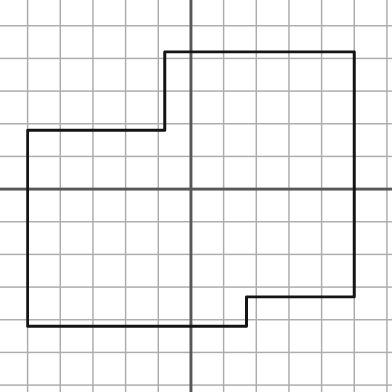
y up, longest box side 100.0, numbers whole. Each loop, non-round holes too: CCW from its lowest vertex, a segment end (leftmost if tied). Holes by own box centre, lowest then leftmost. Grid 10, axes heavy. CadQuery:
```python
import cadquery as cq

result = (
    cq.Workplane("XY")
    .moveTo(-50.0, -42.0)
    .lineTo(17.0, -42.0)
    .lineTo(17.0, -33.0)
    .lineTo(50.0, -33.0)
    .lineTo(50.0, 42.0)
    .lineTo(-8.0, 42.0)
    .lineTo(-8.0, 18.0)
    .lineTo(-50.0, 18.0)
    .close()
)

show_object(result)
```